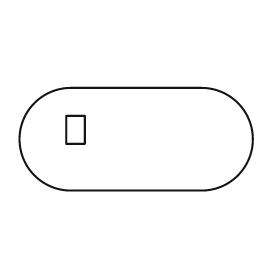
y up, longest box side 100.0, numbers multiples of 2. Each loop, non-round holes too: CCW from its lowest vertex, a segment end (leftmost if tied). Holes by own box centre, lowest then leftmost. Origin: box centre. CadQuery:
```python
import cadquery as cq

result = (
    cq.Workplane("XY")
    .moveTo(-28.0, -22.0)
    .lineTo(28.0, -22.0)
    .threePointArc((50.0, 0.0), (28.0, 22.0))
    .lineTo(-28.0, 22.0)
    .threePointArc((-50.0, 0.0), (-28.0, -22.0))
    .close()
    .moveTo(-30.0, -2.0)
    .lineTo(-22.0, -2.0)
    .lineTo(-22.0, 10.0)
    .lineTo(-30.0, 10.0)
    .close()
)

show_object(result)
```